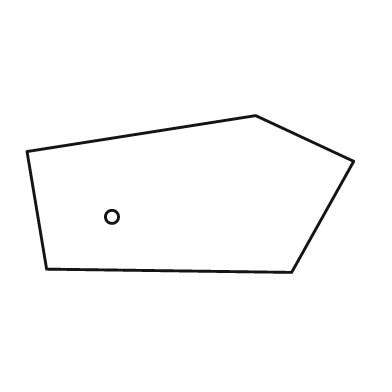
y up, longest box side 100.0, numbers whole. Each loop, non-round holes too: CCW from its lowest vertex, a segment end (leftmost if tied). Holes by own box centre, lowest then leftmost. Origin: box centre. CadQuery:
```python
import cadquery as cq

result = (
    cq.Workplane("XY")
    .moveTo(31.0, -24.0)
    .lineTo(50.0, 10.0)
    .lineTo(20.0, 24.0)
    .lineTo(-50.0, 13.0)
    .lineTo(-44.0, -23.0)
    .close()
    .moveTo(-24.0, -7.0)
    .circle(2.0)
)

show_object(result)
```